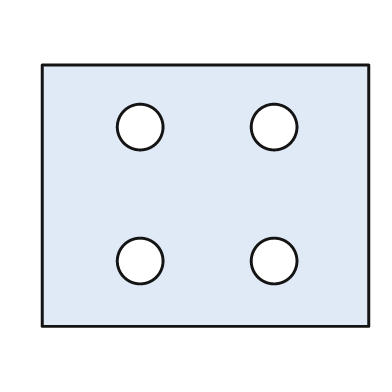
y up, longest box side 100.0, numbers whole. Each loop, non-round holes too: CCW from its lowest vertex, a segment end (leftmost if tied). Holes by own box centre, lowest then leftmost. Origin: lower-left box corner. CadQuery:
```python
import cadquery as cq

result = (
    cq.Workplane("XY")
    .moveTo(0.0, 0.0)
    .lineTo(100.0, 0.0)
    .lineTo(100.0, 80.0)
    .lineTo(0.0, 80.0)
    .close()
    .moveTo(30.0, 20.0)
    .circle(7.0)
    .moveTo(71.0, 20.0)
    .circle(7.0)
    .moveTo(30.0, 61.0)
    .circle(7.0)
    .moveTo(71.0, 61.0)
    .circle(7.0)
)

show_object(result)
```